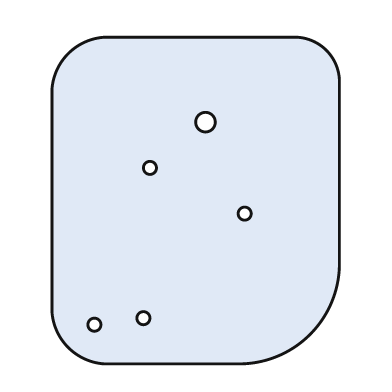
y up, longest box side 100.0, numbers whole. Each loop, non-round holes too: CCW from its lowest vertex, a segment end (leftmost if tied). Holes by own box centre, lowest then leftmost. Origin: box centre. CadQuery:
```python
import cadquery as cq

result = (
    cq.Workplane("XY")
    .moveTo(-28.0, -50.0)
    .lineTo(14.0, -50.0)
    .threePointArc((35.0, -41.0), (44.0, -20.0))
    .lineTo(44.0, 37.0)
    .threePointArc((40.0, 46.0), (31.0, 50.0))
    .lineTo(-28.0, 50.0)
    .threePointArc((-39.0, 45.0), (-44.0, 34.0))
    .lineTo(-44.0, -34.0)
    .threePointArc((-39.0, -45.0), (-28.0, -50.0))
    .close()
    .moveTo(-31.0, -38.0)
    .circle(2.0)
    .moveTo(-16.0, -36.0)
    .circle(2.0)
    .moveTo(15.0, -4.0)
    .circle(2.0)
    .moveTo(-14.0, 10.0)
    .circle(2.0)
    .moveTo(3.0, 24.0)
    .circle(3.0)
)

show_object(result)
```